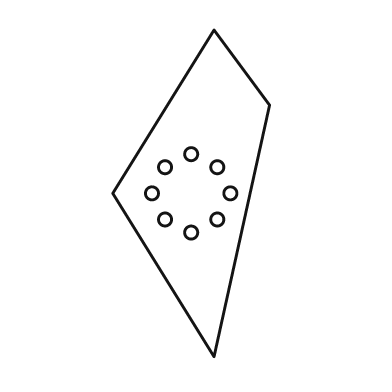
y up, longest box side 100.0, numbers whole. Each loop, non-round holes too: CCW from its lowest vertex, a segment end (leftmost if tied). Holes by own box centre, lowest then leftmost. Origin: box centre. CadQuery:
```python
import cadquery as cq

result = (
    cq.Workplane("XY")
    .moveTo(7.0, -50.0)
    .lineTo(24.0, 27.0)
    .lineTo(7.0, 50.0)
    .lineTo(-24.0, 0.0)
    .close()
    .moveTo(0.0, -12.0)
    .circle(2.0)
    .moveTo(-8.0, -8.0)
    .circle(2.0)
    .moveTo(8.0, -8.0)
    .circle(2.0)
    .moveTo(-12.0, 0.0)
    .circle(2.0)
    .moveTo(12.0, 0.0)
    .circle(2.0)
    .moveTo(-8.0, 8.0)
    .circle(2.0)
    .moveTo(8.0, 8.0)
    .circle(2.0)
    .moveTo(0.0, 12.0)
    .circle(2.0)
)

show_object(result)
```